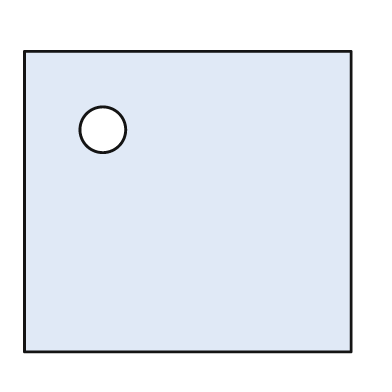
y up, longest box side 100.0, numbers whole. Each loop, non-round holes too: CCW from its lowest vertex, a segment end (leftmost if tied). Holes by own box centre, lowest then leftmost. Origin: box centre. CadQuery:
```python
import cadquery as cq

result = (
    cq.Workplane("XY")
    .moveTo(-50.0, -46.0)
    .lineTo(50.0, -46.0)
    .lineTo(50.0, 46.0)
    .lineTo(-50.0, 46.0)
    .close()
    .moveTo(-26.0, 22.0)
    .circle(7.0)
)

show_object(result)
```